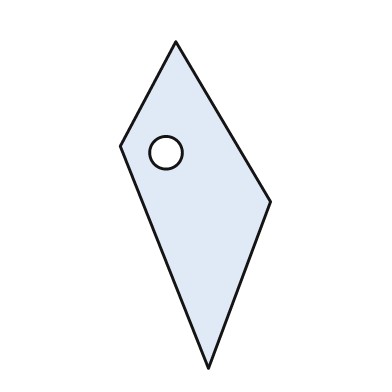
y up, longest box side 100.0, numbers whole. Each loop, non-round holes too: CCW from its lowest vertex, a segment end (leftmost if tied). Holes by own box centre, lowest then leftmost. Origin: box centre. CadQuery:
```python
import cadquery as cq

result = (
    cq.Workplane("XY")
    .moveTo(4.0, -50.0)
    .lineTo(23.0, 1.0)
    .lineTo(-6.0, 50.0)
    .lineTo(-23.0, 18.0)
    .close()
    .moveTo(-9.0, 16.0)
    .circle(5.0)
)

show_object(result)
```